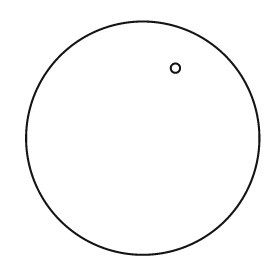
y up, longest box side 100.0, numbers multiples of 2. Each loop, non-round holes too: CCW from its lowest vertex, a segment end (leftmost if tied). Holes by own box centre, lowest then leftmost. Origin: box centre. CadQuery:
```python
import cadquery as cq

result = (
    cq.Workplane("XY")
    .moveTo(0.0, 0.0)
    .circle(50.0)
    .moveTo(14.0, 30.0)
    .circle(2.0)
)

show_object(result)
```